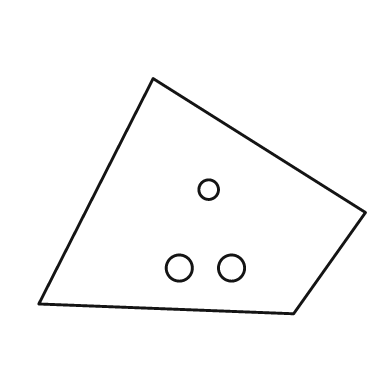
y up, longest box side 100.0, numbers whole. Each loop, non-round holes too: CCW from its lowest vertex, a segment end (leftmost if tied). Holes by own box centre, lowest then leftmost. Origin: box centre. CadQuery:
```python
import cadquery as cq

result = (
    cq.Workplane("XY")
    .moveTo(28.0, -36.0)
    .lineTo(50.0, -5.0)
    .lineTo(-15.0, 36.0)
    .lineTo(-50.0, -33.0)
    .close()
    .moveTo(-7.0, -22.0)
    .circle(4.0)
    .moveTo(9.0, -22.0)
    .circle(4.0)
    .moveTo(2.0, 2.0)
    .circle(3.0)
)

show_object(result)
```